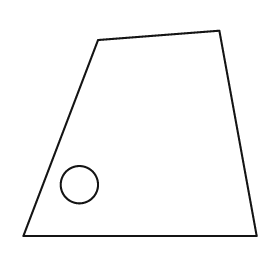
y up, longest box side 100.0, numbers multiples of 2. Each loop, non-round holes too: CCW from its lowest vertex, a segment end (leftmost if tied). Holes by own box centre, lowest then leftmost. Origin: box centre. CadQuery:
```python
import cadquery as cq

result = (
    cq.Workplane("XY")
    .moveTo(-50.0, -44.0)
    .lineTo(50.0, -44.0)
    .lineTo(34.0, 44.0)
    .lineTo(-18.0, 40.0)
    .close()
    .moveTo(-26.0, -22.0)
    .circle(8.0)
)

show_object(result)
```